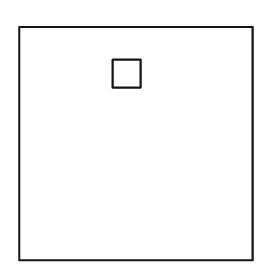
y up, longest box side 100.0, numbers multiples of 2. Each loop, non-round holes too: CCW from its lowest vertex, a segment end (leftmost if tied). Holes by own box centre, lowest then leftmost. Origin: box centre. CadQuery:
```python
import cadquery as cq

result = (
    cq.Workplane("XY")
    .moveTo(-50.0, -50.0)
    .lineTo(50.0, -50.0)
    .lineTo(50.0, 50.0)
    .lineTo(-50.0, 50.0)
    .close()
    .moveTo(-10.0, 24.0)
    .lineTo(2.0, 24.0)
    .lineTo(2.0, 36.0)
    .lineTo(-10.0, 36.0)
    .close()
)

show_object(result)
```